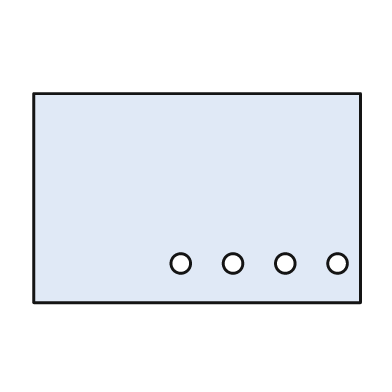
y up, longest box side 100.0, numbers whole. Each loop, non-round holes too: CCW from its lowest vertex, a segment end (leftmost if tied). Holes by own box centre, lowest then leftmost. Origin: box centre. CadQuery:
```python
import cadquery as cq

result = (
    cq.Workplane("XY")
    .moveTo(-50.0, -32.0)
    .lineTo(50.0, -32.0)
    .lineTo(50.0, 32.0)
    .lineTo(-50.0, 32.0)
    .close()
    .moveTo(-5.0, -20.0)
    .circle(3.0)
    .moveTo(11.0, -20.0)
    .circle(3.0)
    .moveTo(27.0, -20.0)
    .circle(3.0)
    .moveTo(43.0, -20.0)
    .circle(3.0)
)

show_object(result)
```